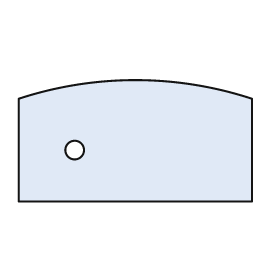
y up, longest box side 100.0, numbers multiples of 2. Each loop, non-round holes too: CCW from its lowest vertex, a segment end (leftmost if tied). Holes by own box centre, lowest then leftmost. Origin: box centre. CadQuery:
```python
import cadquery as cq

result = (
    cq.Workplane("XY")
    .moveTo(-50.0, -26.0)
    .lineTo(50.0, -26.0)
    .lineTo(50.0, 18.0)
    .threePointArc((0.0, 26.0), (-50.0, 18.0))
    .close()
    .moveTo(-26.0, -4.0)
    .circle(4.0)
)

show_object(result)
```